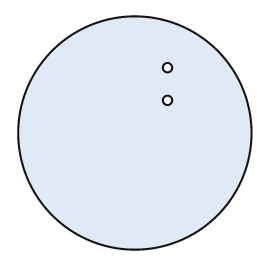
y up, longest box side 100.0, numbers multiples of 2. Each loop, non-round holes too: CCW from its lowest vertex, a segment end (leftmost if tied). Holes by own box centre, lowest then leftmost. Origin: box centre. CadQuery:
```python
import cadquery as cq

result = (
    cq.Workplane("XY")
    .moveTo(0.0, 0.0)
    .circle(50.0)
    .moveTo(14.0, 14.0)
    .circle(2.0)
    .moveTo(14.0, 28.0)
    .circle(2.0)
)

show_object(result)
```